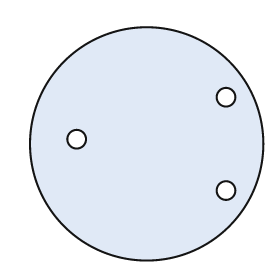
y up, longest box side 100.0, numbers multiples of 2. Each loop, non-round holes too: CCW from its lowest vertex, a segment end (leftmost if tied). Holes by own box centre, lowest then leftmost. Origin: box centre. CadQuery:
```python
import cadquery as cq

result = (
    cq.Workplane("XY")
    .moveTo(0.0, 0.0)
    .circle(50.0)
    .moveTo(34.0, -20.0)
    .circle(4.0)
    .moveTo(-30.0, 2.0)
    .circle(4.0)
    .moveTo(34.0, 20.0)
    .circle(4.0)
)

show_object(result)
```